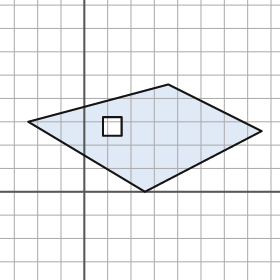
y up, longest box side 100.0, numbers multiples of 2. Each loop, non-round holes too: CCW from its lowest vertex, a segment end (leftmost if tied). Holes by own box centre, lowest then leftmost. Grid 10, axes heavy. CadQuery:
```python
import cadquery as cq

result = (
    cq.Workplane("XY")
    .moveTo(26.0, 0.0)
    .lineTo(76.0, 26.0)
    .lineTo(36.0, 46.0)
    .lineTo(-24.0, 30.0)
    .close()
    .moveTo(8.0, 24.0)
    .lineTo(16.0, 24.0)
    .lineTo(16.0, 32.0)
    .lineTo(8.0, 32.0)
    .close()
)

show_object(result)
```